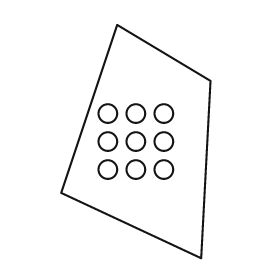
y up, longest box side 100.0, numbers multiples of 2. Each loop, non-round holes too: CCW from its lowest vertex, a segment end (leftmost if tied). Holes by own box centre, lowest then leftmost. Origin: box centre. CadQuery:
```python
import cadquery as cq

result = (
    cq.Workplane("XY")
    .moveTo(28.0, -50.0)
    .lineTo(32.0, 26.0)
    .lineTo(-8.0, 50.0)
    .lineTo(-32.0, -22.0)
    .close()
    .moveTo(-12.0, -12.0)
    .circle(4.0)
    .moveTo(0.0, -12.0)
    .circle(4.0)
    .moveTo(12.0, -12.0)
    .circle(4.0)
    .moveTo(-12.0, 0.0)
    .circle(4.0)
    .moveTo(0.0, 0.0)
    .circle(4.0)
    .moveTo(12.0, 0.0)
    .circle(4.0)
    .moveTo(-12.0, 12.0)
    .circle(4.0)
    .moveTo(0.0, 12.0)
    .circle(4.0)
    .moveTo(12.0, 12.0)
    .circle(4.0)
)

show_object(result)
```